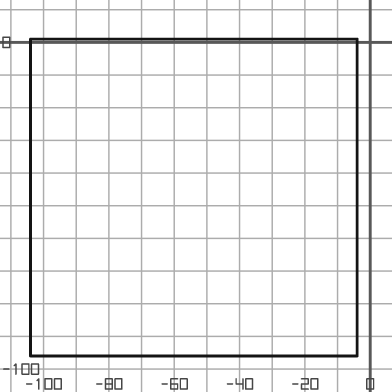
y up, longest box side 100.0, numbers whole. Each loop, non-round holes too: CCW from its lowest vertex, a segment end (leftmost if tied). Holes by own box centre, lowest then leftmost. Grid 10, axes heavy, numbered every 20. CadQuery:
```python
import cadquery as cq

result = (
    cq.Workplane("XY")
    .moveTo(-104.0, -96.0)
    .lineTo(-4.0, -96.0)
    .lineTo(-4.0, 1.0)
    .lineTo(-104.0, 1.0)
    .close()
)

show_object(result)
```